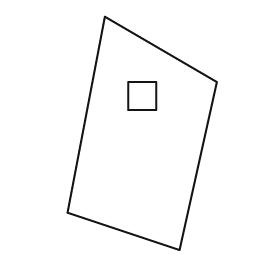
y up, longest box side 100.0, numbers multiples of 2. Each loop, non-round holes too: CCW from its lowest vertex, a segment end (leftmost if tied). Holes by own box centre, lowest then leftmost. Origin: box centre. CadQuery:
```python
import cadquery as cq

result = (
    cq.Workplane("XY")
    .moveTo(16.0, -50.0)
    .lineTo(32.0, 22.0)
    .lineTo(-16.0, 50.0)
    .lineTo(-32.0, -34.0)
    .close()
    .moveTo(-6.0, 10.0)
    .lineTo(6.0, 10.0)
    .lineTo(6.0, 22.0)
    .lineTo(-6.0, 22.0)
    .close()
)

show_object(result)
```